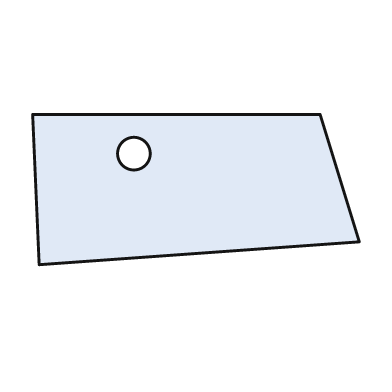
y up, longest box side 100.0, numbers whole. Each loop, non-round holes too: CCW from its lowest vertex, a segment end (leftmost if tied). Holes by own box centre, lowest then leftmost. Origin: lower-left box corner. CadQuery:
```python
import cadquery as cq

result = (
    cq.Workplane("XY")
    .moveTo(2.0, 0.0)
    .lineTo(100.0, 7.0)
    .lineTo(88.0, 46.0)
    .lineTo(0.0, 46.0)
    .close()
    .moveTo(31.0, 34.0)
    .circle(5.0)
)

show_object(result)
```